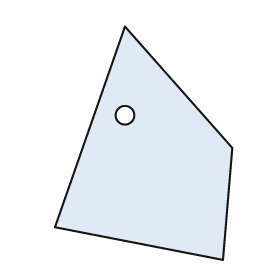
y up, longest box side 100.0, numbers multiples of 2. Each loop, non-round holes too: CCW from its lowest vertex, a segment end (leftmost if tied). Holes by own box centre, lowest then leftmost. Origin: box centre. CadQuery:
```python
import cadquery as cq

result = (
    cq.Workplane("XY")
    .moveTo(34.0, -50.0)
    .lineTo(38.0, -2.0)
    .lineTo(-8.0, 50.0)
    .lineTo(-38.0, -36.0)
    .close()
    .moveTo(-8.0, 12.0)
    .circle(4.0)
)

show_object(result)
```